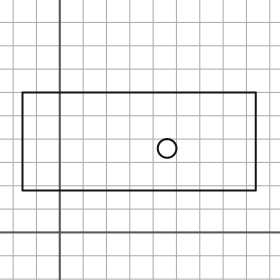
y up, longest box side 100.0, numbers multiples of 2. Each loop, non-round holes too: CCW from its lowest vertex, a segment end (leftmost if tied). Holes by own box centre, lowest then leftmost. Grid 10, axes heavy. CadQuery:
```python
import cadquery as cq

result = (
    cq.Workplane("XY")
    .moveTo(-16.0, 18.0)
    .lineTo(84.0, 18.0)
    .lineTo(84.0, 60.0)
    .lineTo(-16.0, 60.0)
    .close()
    .moveTo(46.0, 36.0)
    .circle(4.0)
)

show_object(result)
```